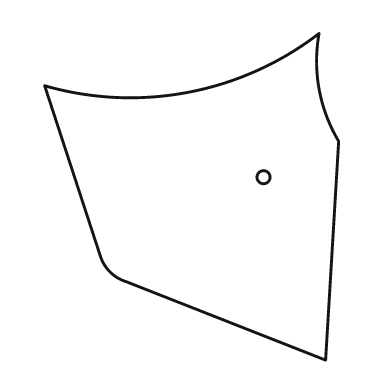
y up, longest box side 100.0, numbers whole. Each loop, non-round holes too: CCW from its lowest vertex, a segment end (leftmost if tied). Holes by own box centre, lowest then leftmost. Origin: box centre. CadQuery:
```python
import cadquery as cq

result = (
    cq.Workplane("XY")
    .moveTo(41.0, -50.0)
    .lineTo(45.0, 17.0)
    .threePointArc((39.0, 33.0), (39.0, 50.0))
    .threePointArc((-1.0, 32.0), (-45.0, 34.0))
    .lineTo(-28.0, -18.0)
    .threePointArc((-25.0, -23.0), (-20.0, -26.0))
    .close()
    .moveTo(22.0, 6.0)
    .circle(2.0)
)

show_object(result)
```